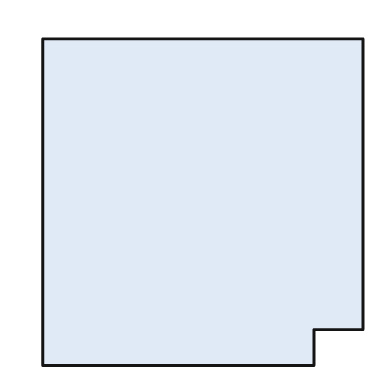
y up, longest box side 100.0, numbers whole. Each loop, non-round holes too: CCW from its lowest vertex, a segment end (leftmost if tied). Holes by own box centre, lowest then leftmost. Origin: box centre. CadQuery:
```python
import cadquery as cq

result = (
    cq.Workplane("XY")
    .moveTo(-49.0, -50.0)
    .lineTo(34.0, -50.0)
    .lineTo(34.0, -39.0)
    .lineTo(49.0, -39.0)
    .lineTo(49.0, 50.0)
    .lineTo(-49.0, 50.0)
    .close()
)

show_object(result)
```